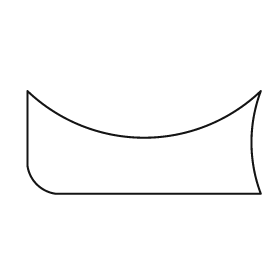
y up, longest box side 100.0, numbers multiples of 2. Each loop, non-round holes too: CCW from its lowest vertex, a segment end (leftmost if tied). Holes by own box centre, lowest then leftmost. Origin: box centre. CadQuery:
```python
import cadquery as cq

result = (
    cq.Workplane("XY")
    .moveTo(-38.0, -22.0)
    .lineTo(50.0, -22.0)
    .threePointArc((46.0, 0.0), (50.0, 22.0))
    .threePointArc((0.0, 2.0), (-50.0, 22.0))
    .lineTo(-50.0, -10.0)
    .threePointArc((-46.0, -18.0), (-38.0, -22.0))
    .close()
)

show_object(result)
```